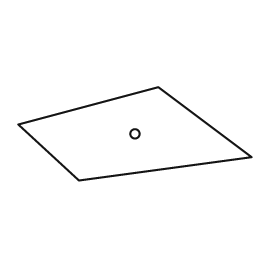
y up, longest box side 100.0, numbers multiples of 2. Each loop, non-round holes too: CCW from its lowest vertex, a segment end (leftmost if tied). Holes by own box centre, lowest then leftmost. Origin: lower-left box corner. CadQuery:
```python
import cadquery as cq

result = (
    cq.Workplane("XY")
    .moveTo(26.0, 0.0)
    .lineTo(100.0, 10.0)
    .lineTo(60.0, 40.0)
    .lineTo(0.0, 24.0)
    .close()
    .moveTo(50.0, 20.0)
    .circle(2.0)
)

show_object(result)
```